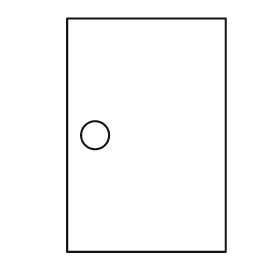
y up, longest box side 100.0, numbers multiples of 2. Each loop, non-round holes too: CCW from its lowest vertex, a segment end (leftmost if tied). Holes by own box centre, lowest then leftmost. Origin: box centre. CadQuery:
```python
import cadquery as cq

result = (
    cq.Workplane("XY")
    .moveTo(-34.0, -50.0)
    .lineTo(34.0, -50.0)
    .lineTo(34.0, 50.0)
    .lineTo(-34.0, 50.0)
    .close()
    .moveTo(-22.0, 0.0)
    .circle(6.0)
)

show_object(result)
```